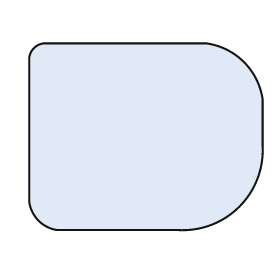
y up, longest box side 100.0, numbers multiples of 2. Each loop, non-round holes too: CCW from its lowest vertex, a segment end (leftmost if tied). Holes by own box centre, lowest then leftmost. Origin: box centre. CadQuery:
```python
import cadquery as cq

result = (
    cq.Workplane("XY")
    .moveTo(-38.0, -40.0)
    .lineTo(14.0, -40.0)
    .threePointArc((40.0, -30.0), (50.0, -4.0))
    .lineTo(50.0, 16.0)
    .threePointArc((42.0, 32.0), (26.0, 40.0))
    .lineTo(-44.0, 40.0)
    .threePointArc((-48.0, 38.0), (-50.0, 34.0))
    .lineTo(-50.0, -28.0)
    .threePointArc((-46.0, -36.0), (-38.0, -40.0))
    .close()
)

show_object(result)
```